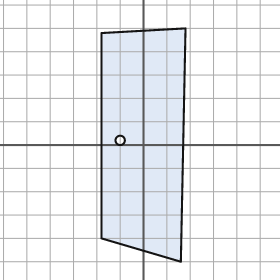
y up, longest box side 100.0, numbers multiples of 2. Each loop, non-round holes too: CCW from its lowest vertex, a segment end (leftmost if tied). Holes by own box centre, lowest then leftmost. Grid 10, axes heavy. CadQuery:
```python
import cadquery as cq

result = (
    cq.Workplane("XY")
    .moveTo(16.0, -50.0)
    .lineTo(18.0, 50.0)
    .lineTo(-18.0, 48.0)
    .lineTo(-18.0, -40.0)
    .close()
    .moveTo(-10.0, 2.0)
    .circle(2.0)
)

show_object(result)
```